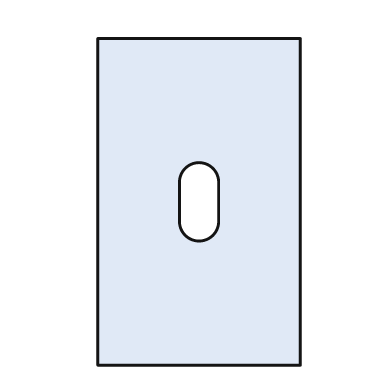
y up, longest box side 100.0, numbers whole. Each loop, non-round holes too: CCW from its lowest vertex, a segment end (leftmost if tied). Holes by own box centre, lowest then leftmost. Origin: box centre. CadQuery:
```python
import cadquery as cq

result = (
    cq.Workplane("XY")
    .moveTo(-31.0, -50.0)
    .lineTo(31.0, -50.0)
    .lineTo(31.0, 50.0)
    .lineTo(-31.0, 50.0)
    .close()
    .moveTo(-6.0, -6.0)
    .threePointArc((0.0, -12.0), (6.0, -6.0))
    .lineTo(6.0, 6.0)
    .threePointArc((0.0, 12.0), (-6.0, 6.0))
    .close()
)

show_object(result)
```